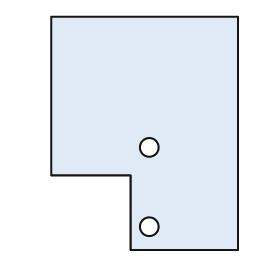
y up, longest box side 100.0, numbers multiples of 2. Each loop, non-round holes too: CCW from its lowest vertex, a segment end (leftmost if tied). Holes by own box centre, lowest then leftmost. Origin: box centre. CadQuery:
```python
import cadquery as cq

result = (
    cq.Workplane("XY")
    .moveTo(-6.0, -50.0)
    .lineTo(40.0, -50.0)
    .lineTo(40.0, 50.0)
    .lineTo(-40.0, 50.0)
    .lineTo(-40.0, -18.0)
    .lineTo(-6.0, -18.0)
    .close()
    .moveTo(2.0, -40.0)
    .circle(4.0)
    .moveTo(2.0, -6.0)
    .circle(4.0)
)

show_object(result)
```